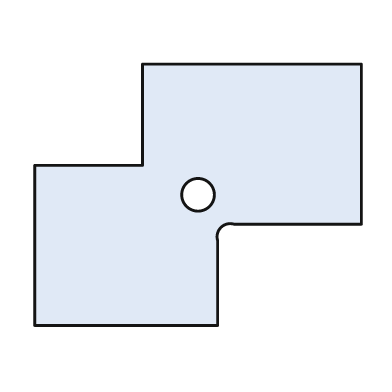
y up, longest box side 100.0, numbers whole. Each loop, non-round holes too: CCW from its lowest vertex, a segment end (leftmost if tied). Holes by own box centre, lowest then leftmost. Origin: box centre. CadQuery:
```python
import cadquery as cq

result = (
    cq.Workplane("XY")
    .moveTo(-50.0, -40.0)
    .lineTo(6.0, -40.0)
    .lineTo(6.0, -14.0)
    .threePointArc((7.0, -10.0), (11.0, -9.0))
    .lineTo(50.0, -9.0)
    .lineTo(50.0, 40.0)
    .lineTo(-17.0, 40.0)
    .lineTo(-17.0, 9.0)
    .lineTo(-50.0, 9.0)
    .close()
    .moveTo(0.0, 0.0)
    .circle(5.0)
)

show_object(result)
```